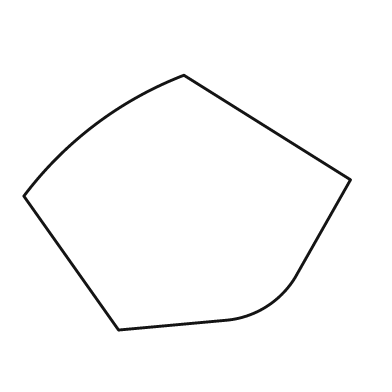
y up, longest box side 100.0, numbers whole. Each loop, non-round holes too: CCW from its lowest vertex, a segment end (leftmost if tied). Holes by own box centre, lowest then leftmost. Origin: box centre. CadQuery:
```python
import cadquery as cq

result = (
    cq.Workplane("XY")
    .moveTo(-21.0, -39.0)
    .lineTo(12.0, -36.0)
    .threePointArc((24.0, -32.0), (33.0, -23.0))
    .lineTo(50.0, 7.0)
    .lineTo(-1.0, 39.0)
    .threePointArc((-28.0, 24.0), (-50.0, 2.0))
    .close()
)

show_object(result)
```